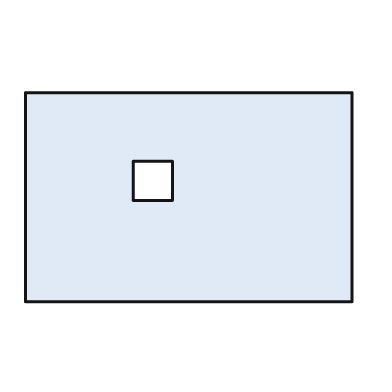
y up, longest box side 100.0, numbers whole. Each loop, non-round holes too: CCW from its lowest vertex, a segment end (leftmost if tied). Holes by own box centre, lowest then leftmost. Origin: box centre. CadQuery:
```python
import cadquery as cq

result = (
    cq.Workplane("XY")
    .moveTo(-50.0, -32.0)
    .lineTo(50.0, -32.0)
    .lineTo(50.0, 32.0)
    .lineTo(-50.0, 32.0)
    .close()
    .moveTo(-17.0, -1.0)
    .lineTo(-5.0, -1.0)
    .lineTo(-5.0, 11.0)
    .lineTo(-17.0, 11.0)
    .close()
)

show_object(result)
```